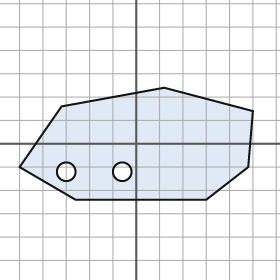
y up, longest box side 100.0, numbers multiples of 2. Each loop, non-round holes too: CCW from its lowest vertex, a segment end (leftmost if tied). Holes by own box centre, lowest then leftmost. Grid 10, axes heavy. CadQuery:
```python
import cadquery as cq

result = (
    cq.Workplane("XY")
    .moveTo(-26.0, -24.0)
    .lineTo(30.0, -24.0)
    .lineTo(48.0, -10.0)
    .lineTo(50.0, 14.0)
    .lineTo(12.0, 24.0)
    .lineTo(-32.0, 16.0)
    .lineTo(-50.0, -10.0)
    .close()
    .moveTo(-30.0, -12.0)
    .circle(4.0)
    .moveTo(-6.0, -12.0)
    .circle(4.0)
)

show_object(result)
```